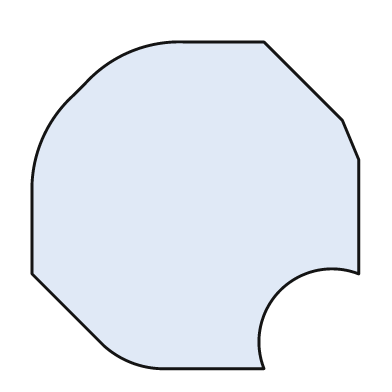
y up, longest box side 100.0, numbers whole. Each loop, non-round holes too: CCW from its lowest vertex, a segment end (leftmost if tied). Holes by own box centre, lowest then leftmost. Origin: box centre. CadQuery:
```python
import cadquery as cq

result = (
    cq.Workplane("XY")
    .moveTo(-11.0, -50.0)
    .lineTo(21.0, -50.0)
    .threePointArc((26.0, -26.0), (50.0, -21.0))
    .lineTo(50.0, 14.0)
    .lineTo(45.0, 26.0)
    .lineTo(21.0, 50.0)
    .lineTo(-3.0, 50.0)
    .threePointArc((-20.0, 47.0), (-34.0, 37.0))
    .lineTo(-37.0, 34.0)
    .threePointArc((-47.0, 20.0), (-50.0, 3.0))
    .lineTo(-50.0, -21.0)
    .lineTo(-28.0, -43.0)
    .threePointArc((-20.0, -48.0), (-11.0, -50.0))
    .close()
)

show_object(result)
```